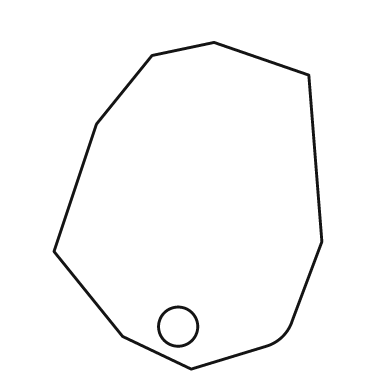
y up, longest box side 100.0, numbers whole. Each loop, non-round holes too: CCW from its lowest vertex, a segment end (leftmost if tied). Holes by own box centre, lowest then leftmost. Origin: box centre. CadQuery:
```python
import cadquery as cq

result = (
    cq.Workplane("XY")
    .moveTo(1.0, -50.0)
    .lineTo(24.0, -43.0)
    .threePointArc((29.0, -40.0), (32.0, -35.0))
    .lineTo(41.0, -11.0)
    .lineTo(37.0, 40.0)
    .lineTo(8.0, 50.0)
    .lineTo(-11.0, 46.0)
    .lineTo(-28.0, 25.0)
    .lineTo(-41.0, -14.0)
    .lineTo(-20.0, -40.0)
    .close()
    .moveTo(-3.0, -37.0)
    .circle(6.0)
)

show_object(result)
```